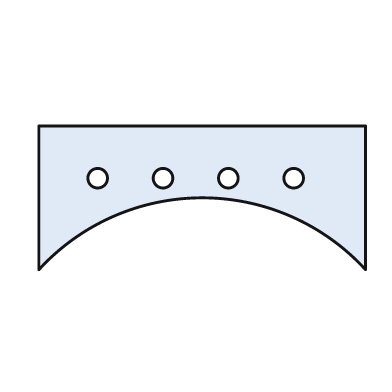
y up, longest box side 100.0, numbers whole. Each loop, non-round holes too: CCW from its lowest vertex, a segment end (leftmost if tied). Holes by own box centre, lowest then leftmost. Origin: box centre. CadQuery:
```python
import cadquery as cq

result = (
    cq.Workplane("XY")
    .moveTo(-50.0, -22.0)
    .threePointArc((0.0, 0.0), (50.0, -22.0))
    .lineTo(50.0, 22.0)
    .lineTo(-50.0, 22.0)
    .close()
    .moveTo(-32.0, 6.0)
    .circle(3.0)
    .moveTo(-12.0, 6.0)
    .circle(3.0)
    .moveTo(8.0, 6.0)
    .circle(3.0)
    .moveTo(28.0, 6.0)
    .circle(3.0)
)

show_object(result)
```